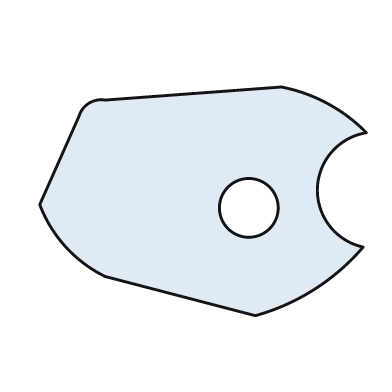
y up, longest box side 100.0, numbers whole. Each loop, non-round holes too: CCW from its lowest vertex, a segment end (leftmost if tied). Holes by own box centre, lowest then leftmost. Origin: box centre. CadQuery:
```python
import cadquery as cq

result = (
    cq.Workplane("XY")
    .moveTo(16.0, -35.0)
    .threePointArc((34.0, -27.0), (49.0, -14.0))
    .threePointArc((35.0, 4.0), (50.0, 21.0))
    .threePointArc((38.0, 30.0), (24.0, 35.0))
    .lineTo(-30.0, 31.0)
    .threePointArc((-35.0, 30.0), (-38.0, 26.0))
    .lineTo(-50.0, -1.0)
    .threePointArc((-42.0, -14.0), (-30.0, -23.0))
    .close()
    .moveTo(14.0, -2.0)
    .circle(9.0)
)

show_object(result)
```